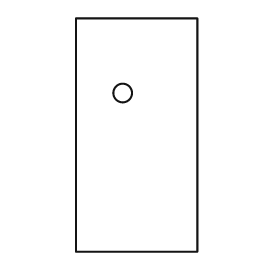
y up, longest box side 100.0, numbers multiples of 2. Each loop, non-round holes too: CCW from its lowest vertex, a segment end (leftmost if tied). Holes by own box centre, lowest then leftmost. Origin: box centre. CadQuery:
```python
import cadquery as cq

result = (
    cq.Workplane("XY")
    .moveTo(-26.0, -50.0)
    .lineTo(26.0, -50.0)
    .lineTo(26.0, 50.0)
    .lineTo(-26.0, 50.0)
    .close()
    .moveTo(-6.0, 18.0)
    .circle(4.0)
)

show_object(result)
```